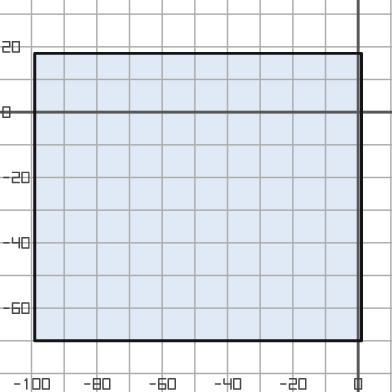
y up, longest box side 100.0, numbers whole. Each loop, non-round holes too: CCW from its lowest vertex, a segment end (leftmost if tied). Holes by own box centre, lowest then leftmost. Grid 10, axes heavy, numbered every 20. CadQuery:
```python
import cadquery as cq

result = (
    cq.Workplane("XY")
    .moveTo(-99.0, -70.0)
    .lineTo(1.0, -70.0)
    .lineTo(1.0, 18.0)
    .lineTo(-99.0, 18.0)
    .close()
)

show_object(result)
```